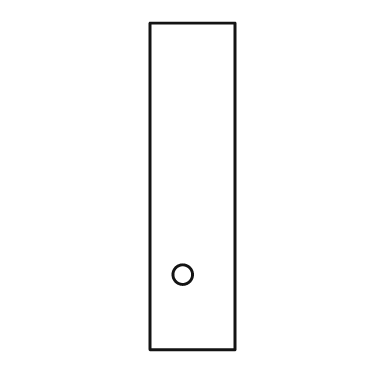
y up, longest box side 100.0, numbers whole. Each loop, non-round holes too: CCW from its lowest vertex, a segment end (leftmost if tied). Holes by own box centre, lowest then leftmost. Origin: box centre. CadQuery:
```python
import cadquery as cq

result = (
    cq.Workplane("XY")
    .moveTo(-13.0, -50.0)
    .lineTo(13.0, -50.0)
    .lineTo(13.0, 50.0)
    .lineTo(-13.0, 50.0)
    .close()
    .moveTo(-3.0, -27.0)
    .circle(3.0)
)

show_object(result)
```